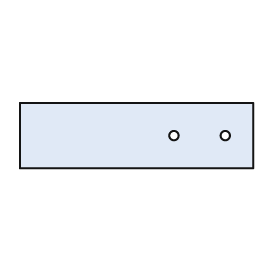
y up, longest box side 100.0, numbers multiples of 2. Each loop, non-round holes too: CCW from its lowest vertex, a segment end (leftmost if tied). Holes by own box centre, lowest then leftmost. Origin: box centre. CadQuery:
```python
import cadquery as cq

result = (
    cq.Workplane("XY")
    .moveTo(-50.0, -14.0)
    .lineTo(50.0, -14.0)
    .lineTo(50.0, 14.0)
    .lineTo(-50.0, 14.0)
    .close()
    .moveTo(16.0, 0.0)
    .circle(2.0)
    .moveTo(38.0, 0.0)
    .circle(2.0)
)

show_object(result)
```